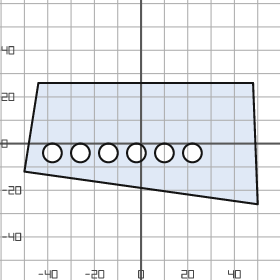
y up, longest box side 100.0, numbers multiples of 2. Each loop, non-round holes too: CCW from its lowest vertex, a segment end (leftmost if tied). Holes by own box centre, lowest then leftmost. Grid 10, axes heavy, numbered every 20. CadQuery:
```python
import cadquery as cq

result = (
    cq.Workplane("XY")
    .moveTo(50.0, -26.0)
    .lineTo(48.0, 26.0)
    .lineTo(-44.0, 26.0)
    .lineTo(-50.0, -12.0)
    .close()
    .moveTo(-38.0, -4.0)
    .circle(4.0)
    .moveTo(-26.0, -4.0)
    .circle(4.0)
    .moveTo(-14.0, -4.0)
    .circle(4.0)
    .moveTo(-2.0, -4.0)
    .circle(4.0)
    .moveTo(10.0, -4.0)
    .circle(4.0)
    .moveTo(22.0, -4.0)
    .circle(4.0)
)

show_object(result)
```